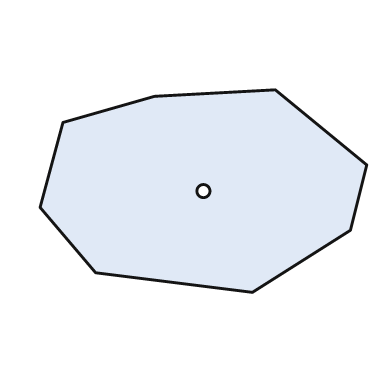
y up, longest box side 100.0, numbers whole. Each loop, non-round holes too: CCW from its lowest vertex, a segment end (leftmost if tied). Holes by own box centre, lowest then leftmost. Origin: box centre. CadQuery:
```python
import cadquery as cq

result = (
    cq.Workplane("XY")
    .moveTo(15.0, -31.0)
    .lineTo(45.0, -12.0)
    .lineTo(50.0, 8.0)
    .lineTo(22.0, 31.0)
    .lineTo(-15.0, 29.0)
    .lineTo(-43.0, 21.0)
    .lineTo(-50.0, -5.0)
    .lineTo(-33.0, -25.0)
    .close()
    .moveTo(0.0, 0.0)
    .circle(2.0)
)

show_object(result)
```